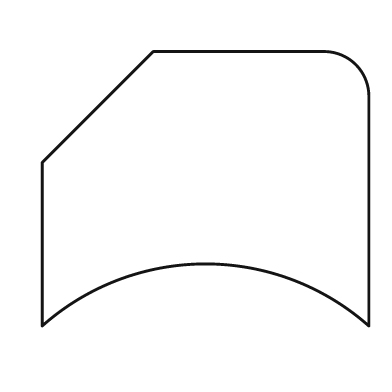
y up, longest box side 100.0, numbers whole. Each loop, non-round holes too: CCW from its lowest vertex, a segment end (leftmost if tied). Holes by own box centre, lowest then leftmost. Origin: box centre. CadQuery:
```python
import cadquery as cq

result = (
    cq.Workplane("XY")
    .moveTo(-50.0, -42.0)
    .threePointArc((0.0, -23.0), (50.0, -42.0))
    .lineTo(50.0, 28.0)
    .threePointArc((46.0, 38.0), (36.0, 42.0))
    .lineTo(-16.0, 42.0)
    .lineTo(-50.0, 8.0)
    .close()
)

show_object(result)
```